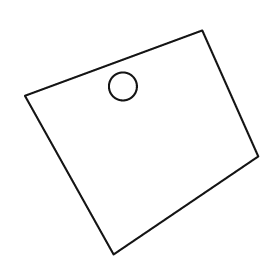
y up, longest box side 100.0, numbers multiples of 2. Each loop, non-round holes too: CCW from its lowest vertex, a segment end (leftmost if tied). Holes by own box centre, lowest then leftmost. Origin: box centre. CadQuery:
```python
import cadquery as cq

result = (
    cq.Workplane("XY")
    .moveTo(-12.0, -48.0)
    .lineTo(50.0, -6.0)
    .lineTo(26.0, 48.0)
    .lineTo(-50.0, 20.0)
    .close()
    .moveTo(-8.0, 24.0)
    .circle(6.0)
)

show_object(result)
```